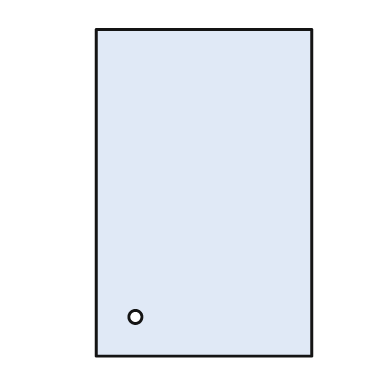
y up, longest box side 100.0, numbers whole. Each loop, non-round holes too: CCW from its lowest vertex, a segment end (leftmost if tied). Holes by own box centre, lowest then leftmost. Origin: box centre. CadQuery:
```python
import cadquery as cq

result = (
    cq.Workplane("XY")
    .moveTo(-33.0, -50.0)
    .lineTo(33.0, -50.0)
    .lineTo(33.0, 50.0)
    .lineTo(-33.0, 50.0)
    .close()
    .moveTo(-21.0, -38.0)
    .circle(2.0)
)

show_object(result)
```